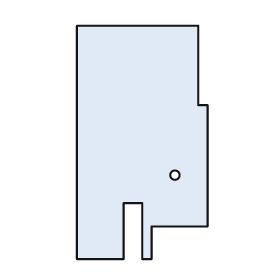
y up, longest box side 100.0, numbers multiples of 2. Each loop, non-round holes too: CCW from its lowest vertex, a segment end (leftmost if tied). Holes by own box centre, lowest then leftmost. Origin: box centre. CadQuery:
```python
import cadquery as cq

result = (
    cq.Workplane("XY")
    .moveTo(-28.0, -50.0)
    .lineTo(-8.0, -50.0)
    .lineTo(-8.0, -26.0)
    .lineTo(0.0, -26.0)
    .lineTo(0.0, -50.0)
    .lineTo(4.0, -50.0)
    .lineTo(4.0, -36.0)
    .lineTo(28.0, -36.0)
    .lineTo(28.0, 16.0)
    .lineTo(24.0, 16.0)
    .lineTo(24.0, 50.0)
    .lineTo(-28.0, 50.0)
    .close()
    .moveTo(14.0, -14.0)
    .circle(2.0)
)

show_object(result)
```